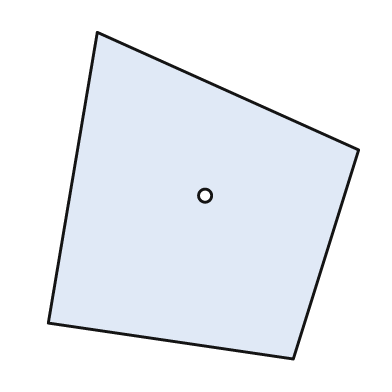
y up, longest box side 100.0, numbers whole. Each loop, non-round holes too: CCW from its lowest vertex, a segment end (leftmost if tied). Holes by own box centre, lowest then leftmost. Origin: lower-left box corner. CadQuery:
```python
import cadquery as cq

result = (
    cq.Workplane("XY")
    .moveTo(75.0, 0.0)
    .lineTo(95.0, 64.0)
    .lineTo(15.0, 100.0)
    .lineTo(0.0, 11.0)
    .close()
    .moveTo(48.0, 50.0)
    .circle(2.0)
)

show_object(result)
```